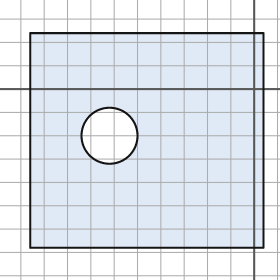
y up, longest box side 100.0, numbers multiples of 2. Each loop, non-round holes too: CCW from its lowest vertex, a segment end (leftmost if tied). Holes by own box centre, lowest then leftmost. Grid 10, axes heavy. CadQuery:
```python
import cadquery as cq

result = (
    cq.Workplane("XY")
    .moveTo(-96.0, -68.0)
    .lineTo(4.0, -68.0)
    .lineTo(4.0, 24.0)
    .lineTo(-96.0, 24.0)
    .close()
    .moveTo(-62.0, -20.0)
    .circle(12.0)
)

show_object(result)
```